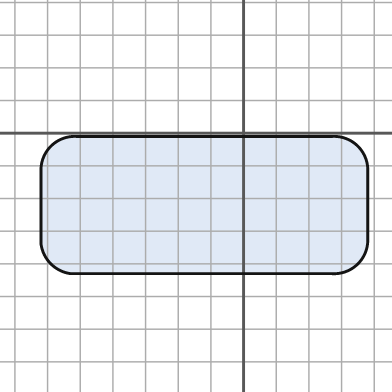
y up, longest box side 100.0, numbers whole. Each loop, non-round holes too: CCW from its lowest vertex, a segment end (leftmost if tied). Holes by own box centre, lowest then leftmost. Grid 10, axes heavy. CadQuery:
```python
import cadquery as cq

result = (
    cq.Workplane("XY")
    .moveTo(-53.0, -43.0)
    .lineTo(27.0, -43.0)
    .threePointArc((35.0, -40.0), (38.0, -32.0))
    .lineTo(38.0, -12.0)
    .threePointArc((35.0, -4.0), (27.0, -1.0))
    .lineTo(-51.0, -1.0)
    .threePointArc((-59.0, -4.0), (-62.0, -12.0))
    .lineTo(-62.0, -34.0)
    .threePointArc((-59.0, -40.0), (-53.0, -43.0))
    .close()
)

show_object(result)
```